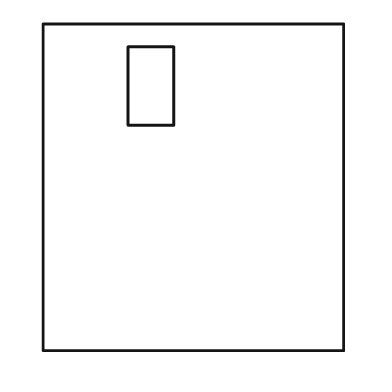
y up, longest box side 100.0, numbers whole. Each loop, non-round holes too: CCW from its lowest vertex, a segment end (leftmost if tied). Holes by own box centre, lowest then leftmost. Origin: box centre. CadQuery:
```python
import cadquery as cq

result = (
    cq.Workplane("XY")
    .moveTo(-46.0, -50.0)
    .lineTo(46.0, -50.0)
    .lineTo(46.0, 50.0)
    .lineTo(-46.0, 50.0)
    .close()
    .moveTo(-20.0, 19.0)
    .lineTo(-6.0, 19.0)
    .lineTo(-6.0, 43.0)
    .lineTo(-20.0, 43.0)
    .close()
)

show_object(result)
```